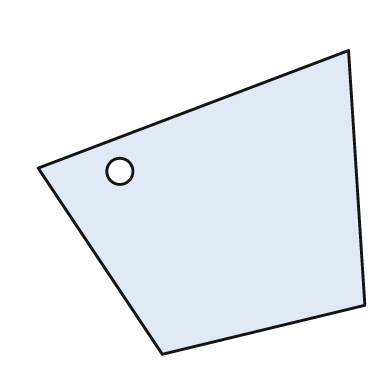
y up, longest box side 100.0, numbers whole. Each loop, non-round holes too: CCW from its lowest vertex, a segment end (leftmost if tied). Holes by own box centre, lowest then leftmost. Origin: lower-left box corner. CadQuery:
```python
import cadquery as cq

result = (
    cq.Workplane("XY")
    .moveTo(38.0, 0.0)
    .lineTo(100.0, 15.0)
    .lineTo(95.0, 93.0)
    .lineTo(0.0, 57.0)
    .close()
    .moveTo(25.0, 56.0)
    .circle(4.0)
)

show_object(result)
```